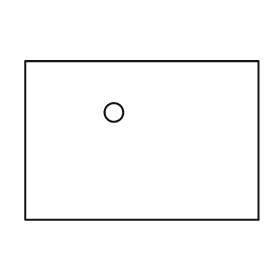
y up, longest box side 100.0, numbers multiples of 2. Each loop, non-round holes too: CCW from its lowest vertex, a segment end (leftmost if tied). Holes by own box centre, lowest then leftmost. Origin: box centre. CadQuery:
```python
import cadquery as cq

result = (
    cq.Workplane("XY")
    .moveTo(-50.0, -34.0)
    .lineTo(50.0, -34.0)
    .lineTo(50.0, 34.0)
    .lineTo(-50.0, 34.0)
    .close()
    .moveTo(-12.0, 12.0)
    .circle(4.0)
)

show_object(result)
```